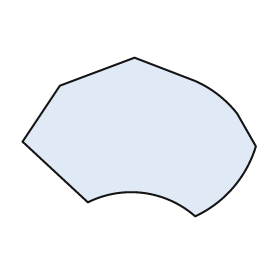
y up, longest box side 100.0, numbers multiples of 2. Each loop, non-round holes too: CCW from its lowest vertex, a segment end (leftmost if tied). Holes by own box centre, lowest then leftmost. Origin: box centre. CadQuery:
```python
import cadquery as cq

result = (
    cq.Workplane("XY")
    .moveTo(24.0, -34.0)
    .threePointArc((40.0, -22.0), (50.0, -4.0))
    .lineTo(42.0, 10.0)
    .threePointArc((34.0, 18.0), (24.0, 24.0))
    .lineTo(-2.0, 34.0)
    .lineTo(-34.0, 22.0)
    .lineTo(-50.0, -2.0)
    .lineTo(-22.0, -28.0)
    .threePointArc((2.0, -24.0), (24.0, -34.0))
    .close()
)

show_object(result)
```